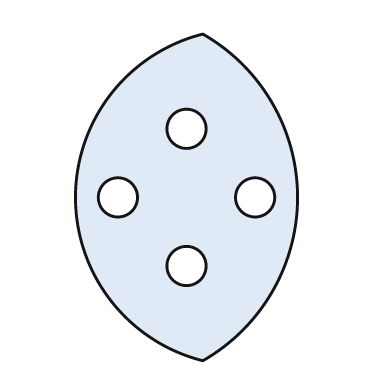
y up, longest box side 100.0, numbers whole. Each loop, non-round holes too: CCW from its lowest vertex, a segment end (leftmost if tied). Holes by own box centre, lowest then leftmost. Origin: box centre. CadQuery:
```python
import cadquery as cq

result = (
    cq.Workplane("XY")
    .moveTo(5.0, -50.0)
    .threePointArc((34.0, 0.0), (5.0, 50.0))
    .threePointArc((-34.0, 0.0), (5.0, -50.0))
    .close()
    .moveTo(0.0, -21.0)
    .circle(6.0)
    .moveTo(-21.0, 0.0)
    .circle(6.0)
    .moveTo(21.0, 0.0)
    .circle(6.0)
    .moveTo(0.0, 21.0)
    .circle(6.0)
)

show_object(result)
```